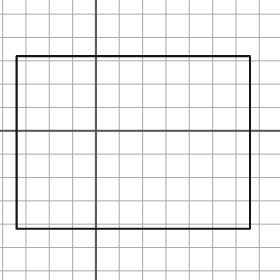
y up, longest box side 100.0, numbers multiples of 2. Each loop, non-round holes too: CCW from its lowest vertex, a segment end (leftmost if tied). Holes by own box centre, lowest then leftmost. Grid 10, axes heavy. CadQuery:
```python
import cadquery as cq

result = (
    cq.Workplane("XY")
    .moveTo(-34.0, -42.0)
    .lineTo(66.0, -42.0)
    .lineTo(66.0, 32.0)
    .lineTo(-34.0, 32.0)
    .close()
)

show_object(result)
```